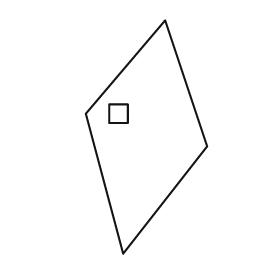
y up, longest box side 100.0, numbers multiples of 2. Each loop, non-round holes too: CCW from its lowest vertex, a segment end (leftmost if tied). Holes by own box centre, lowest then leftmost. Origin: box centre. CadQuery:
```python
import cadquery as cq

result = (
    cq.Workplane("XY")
    .moveTo(-10.0, -50.0)
    .lineTo(26.0, -4.0)
    .lineTo(8.0, 50.0)
    .lineTo(-26.0, 10.0)
    .close()
    .moveTo(-16.0, 6.0)
    .lineTo(-8.0, 6.0)
    .lineTo(-8.0, 14.0)
    .lineTo(-16.0, 14.0)
    .close()
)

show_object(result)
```